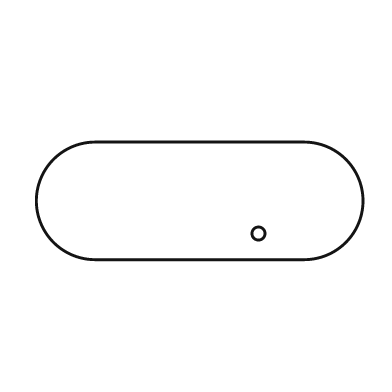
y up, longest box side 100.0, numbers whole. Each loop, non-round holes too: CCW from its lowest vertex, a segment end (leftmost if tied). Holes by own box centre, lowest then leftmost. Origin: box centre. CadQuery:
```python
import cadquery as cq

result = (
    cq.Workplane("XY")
    .moveTo(-32.0, -18.0)
    .lineTo(32.0, -18.0)
    .threePointArc((50.0, 0.0), (32.0, 18.0))
    .lineTo(-32.0, 18.0)
    .threePointArc((-50.0, 0.0), (-32.0, -18.0))
    .close()
    .moveTo(18.0, -10.0)
    .circle(2.0)
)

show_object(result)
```